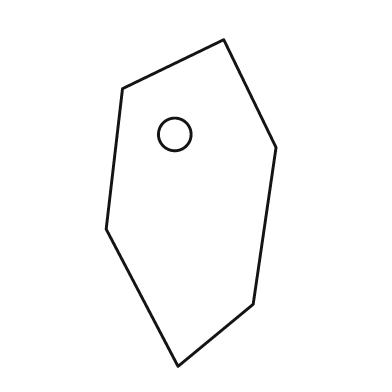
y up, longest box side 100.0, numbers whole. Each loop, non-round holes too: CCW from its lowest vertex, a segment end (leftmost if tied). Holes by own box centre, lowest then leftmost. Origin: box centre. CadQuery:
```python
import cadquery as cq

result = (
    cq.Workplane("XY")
    .moveTo(-4.0, -50.0)
    .lineTo(19.0, -31.0)
    .lineTo(26.0, 17.0)
    .lineTo(10.0, 50.0)
    .lineTo(-21.0, 35.0)
    .lineTo(-26.0, -8.0)
    .close()
    .moveTo(-5.0, 21.0)
    .circle(5.0)
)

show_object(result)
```